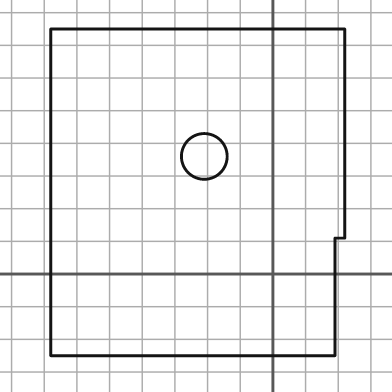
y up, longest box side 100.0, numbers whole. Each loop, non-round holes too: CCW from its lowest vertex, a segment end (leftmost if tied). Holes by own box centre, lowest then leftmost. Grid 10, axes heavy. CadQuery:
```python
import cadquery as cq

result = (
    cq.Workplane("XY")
    .moveTo(-68.0, -25.0)
    .lineTo(19.0, -25.0)
    .lineTo(19.0, 11.0)
    .lineTo(22.0, 11.0)
    .lineTo(22.0, 75.0)
    .lineTo(-68.0, 75.0)
    .close()
    .moveTo(-21.0, 36.0)
    .circle(7.0)
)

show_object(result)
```